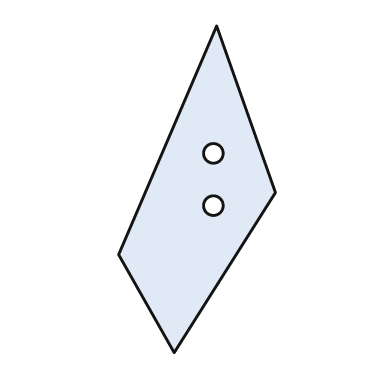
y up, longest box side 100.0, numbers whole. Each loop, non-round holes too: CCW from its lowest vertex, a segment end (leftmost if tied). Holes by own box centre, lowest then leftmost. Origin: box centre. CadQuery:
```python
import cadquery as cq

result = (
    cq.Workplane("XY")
    .moveTo(-7.0, -50.0)
    .lineTo(24.0, -1.0)
    .lineTo(6.0, 50.0)
    .lineTo(-24.0, -20.0)
    .close()
    .moveTo(5.0, -5.0)
    .circle(3.0)
    .moveTo(5.0, 11.0)
    .circle(3.0)
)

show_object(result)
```